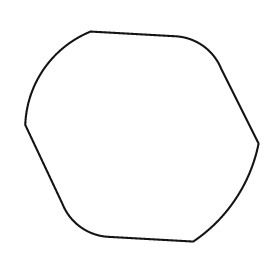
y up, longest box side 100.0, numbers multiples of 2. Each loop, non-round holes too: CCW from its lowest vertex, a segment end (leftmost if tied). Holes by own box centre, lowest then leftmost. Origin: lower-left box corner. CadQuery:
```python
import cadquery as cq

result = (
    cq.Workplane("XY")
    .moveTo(72.0, 0.0)
    .threePointArc((90.0, 18.0), (100.0, 42.0))
    .lineTo(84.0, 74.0)
    .threePointArc((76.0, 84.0), (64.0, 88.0))
    .lineTo(28.0, 90.0)
    .threePointArc((8.0, 74.0), (0.0, 50.0))
    .lineTo(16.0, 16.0)
    .threePointArc((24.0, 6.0), (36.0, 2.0))
    .close()
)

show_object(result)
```